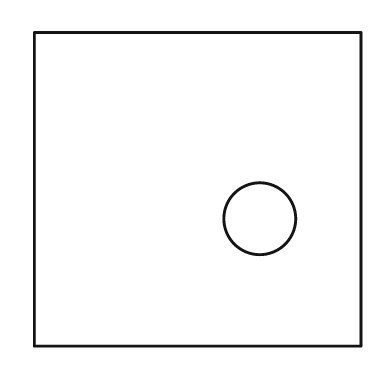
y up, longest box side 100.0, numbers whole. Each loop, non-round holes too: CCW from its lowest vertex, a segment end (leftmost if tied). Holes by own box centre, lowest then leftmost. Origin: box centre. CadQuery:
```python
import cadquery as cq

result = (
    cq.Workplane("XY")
    .moveTo(-50.0, -48.0)
    .lineTo(50.0, -48.0)
    .lineTo(50.0, 48.0)
    .lineTo(-50.0, 48.0)
    .close()
    .moveTo(19.0, -9.0)
    .circle(11.0)
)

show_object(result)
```